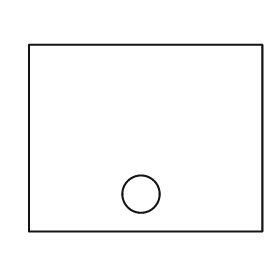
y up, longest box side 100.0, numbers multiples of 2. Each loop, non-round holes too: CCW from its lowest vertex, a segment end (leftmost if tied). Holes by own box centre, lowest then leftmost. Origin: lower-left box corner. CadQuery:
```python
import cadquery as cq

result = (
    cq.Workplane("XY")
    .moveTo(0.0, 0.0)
    .lineTo(100.0, 0.0)
    .lineTo(100.0, 80.0)
    .lineTo(0.0, 80.0)
    .close()
    .moveTo(48.0, 16.0)
    .circle(8.0)
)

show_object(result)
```